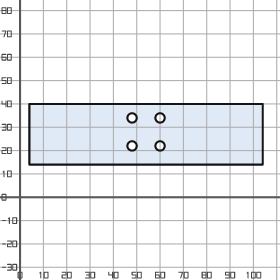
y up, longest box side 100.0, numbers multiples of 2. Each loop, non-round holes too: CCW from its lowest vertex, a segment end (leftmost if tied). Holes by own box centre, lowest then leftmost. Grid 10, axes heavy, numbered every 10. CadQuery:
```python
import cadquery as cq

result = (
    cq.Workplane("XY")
    .moveTo(4.0, 14.0)
    .lineTo(104.0, 14.0)
    .lineTo(104.0, 40.0)
    .lineTo(4.0, 40.0)
    .close()
    .moveTo(48.0, 22.0)
    .circle(2.0)
    .moveTo(60.0, 22.0)
    .circle(2.0)
    .moveTo(48.0, 34.0)
    .circle(2.0)
    .moveTo(60.0, 34.0)
    .circle(2.0)
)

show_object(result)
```